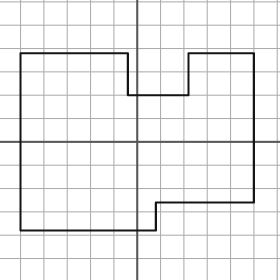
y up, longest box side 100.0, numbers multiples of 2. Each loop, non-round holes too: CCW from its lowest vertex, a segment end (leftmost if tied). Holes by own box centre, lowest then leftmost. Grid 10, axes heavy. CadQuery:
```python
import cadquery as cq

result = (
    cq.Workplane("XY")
    .moveTo(-50.0, -38.0)
    .lineTo(8.0, -38.0)
    .lineTo(8.0, -26.0)
    .lineTo(50.0, -26.0)
    .lineTo(50.0, 38.0)
    .lineTo(22.0, 38.0)
    .lineTo(22.0, 20.0)
    .lineTo(-4.0, 20.0)
    .lineTo(-4.0, 38.0)
    .lineTo(-50.0, 38.0)
    .close()
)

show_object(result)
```